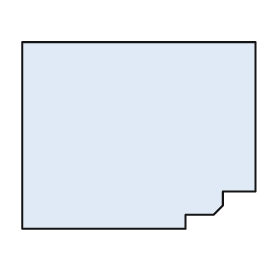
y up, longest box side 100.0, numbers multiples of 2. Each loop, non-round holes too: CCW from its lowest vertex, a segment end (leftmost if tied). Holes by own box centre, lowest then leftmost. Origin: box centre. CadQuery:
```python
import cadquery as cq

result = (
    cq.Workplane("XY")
    .moveTo(-50.0, -40.0)
    .lineTo(20.0, -40.0)
    .lineTo(20.0, -34.0)
    .lineTo(32.0, -34.0)
    .lineTo(36.0, -30.0)
    .lineTo(36.0, -24.0)
    .lineTo(50.0, -24.0)
    .lineTo(50.0, 40.0)
    .lineTo(-50.0, 40.0)
    .close()
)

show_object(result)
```